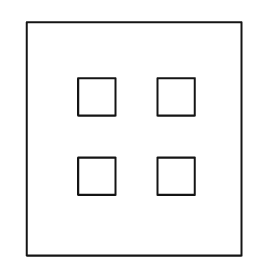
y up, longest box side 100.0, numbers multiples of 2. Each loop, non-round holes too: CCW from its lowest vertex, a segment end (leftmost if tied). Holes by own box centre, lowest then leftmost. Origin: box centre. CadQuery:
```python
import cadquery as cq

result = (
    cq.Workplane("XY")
    .moveTo(-46.0, -50.0)
    .lineTo(46.0, -50.0)
    .lineTo(46.0, 50.0)
    .lineTo(-46.0, 50.0)
    .close()
    .moveTo(-24.0, -24.0)
    .lineTo(-8.0, -24.0)
    .lineTo(-8.0, -8.0)
    .lineTo(-24.0, -8.0)
    .close()
    .moveTo(10.0, -24.0)
    .lineTo(26.0, -24.0)
    .lineTo(26.0, -8.0)
    .lineTo(10.0, -8.0)
    .close()
    .moveTo(-24.0, 10.0)
    .lineTo(-8.0, 10.0)
    .lineTo(-8.0, 26.0)
    .lineTo(-24.0, 26.0)
    .close()
    .moveTo(10.0, 10.0)
    .lineTo(26.0, 10.0)
    .lineTo(26.0, 26.0)
    .lineTo(10.0, 26.0)
    .close()
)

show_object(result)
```